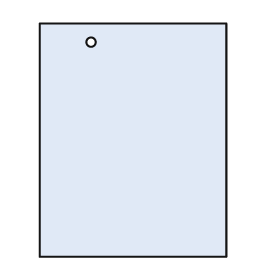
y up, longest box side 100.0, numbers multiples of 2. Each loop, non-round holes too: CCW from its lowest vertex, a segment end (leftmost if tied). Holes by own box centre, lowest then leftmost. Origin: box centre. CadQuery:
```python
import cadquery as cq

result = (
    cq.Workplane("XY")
    .moveTo(-40.0, -50.0)
    .lineTo(40.0, -50.0)
    .lineTo(40.0, 50.0)
    .lineTo(-40.0, 50.0)
    .close()
    .moveTo(-18.0, 42.0)
    .circle(2.0)
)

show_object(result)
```